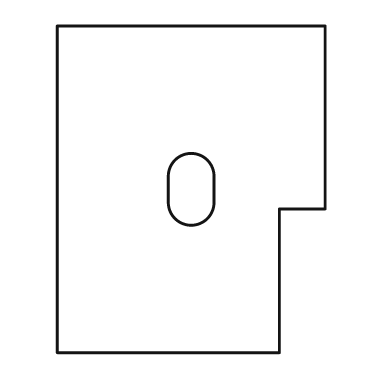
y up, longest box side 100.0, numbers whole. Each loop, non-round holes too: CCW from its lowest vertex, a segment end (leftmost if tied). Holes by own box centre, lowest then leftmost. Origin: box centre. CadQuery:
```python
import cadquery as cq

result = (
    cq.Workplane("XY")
    .moveTo(-41.0, -50.0)
    .lineTo(27.0, -50.0)
    .lineTo(27.0, -6.0)
    .lineTo(41.0, -6.0)
    .lineTo(41.0, 50.0)
    .lineTo(-41.0, 50.0)
    .close()
    .moveTo(-7.0, -4.0)
    .threePointArc((0.0, -11.0), (7.0, -4.0))
    .lineTo(7.0, 4.0)
    .threePointArc((0.0, 11.0), (-7.0, 4.0))
    .close()
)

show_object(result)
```